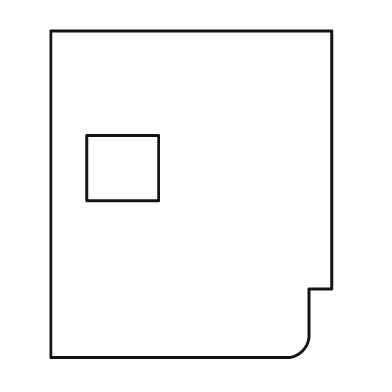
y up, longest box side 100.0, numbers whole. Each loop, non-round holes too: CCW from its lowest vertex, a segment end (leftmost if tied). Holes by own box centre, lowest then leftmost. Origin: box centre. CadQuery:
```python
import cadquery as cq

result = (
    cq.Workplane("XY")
    .moveTo(-43.0, -50.0)
    .lineTo(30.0, -50.0)
    .threePointArc((34.0, -48.0), (36.0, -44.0))
    .lineTo(36.0, -29.0)
    .lineTo(43.0, -29.0)
    .lineTo(43.0, 50.0)
    .lineTo(-43.0, 50.0)
    .close()
    .moveTo(-32.0, -2.0)
    .lineTo(-10.0, -2.0)
    .lineTo(-10.0, 18.0)
    .lineTo(-32.0, 18.0)
    .close()
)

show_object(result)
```